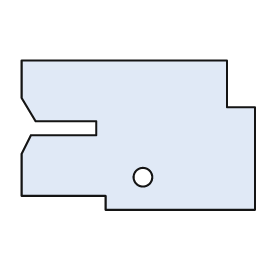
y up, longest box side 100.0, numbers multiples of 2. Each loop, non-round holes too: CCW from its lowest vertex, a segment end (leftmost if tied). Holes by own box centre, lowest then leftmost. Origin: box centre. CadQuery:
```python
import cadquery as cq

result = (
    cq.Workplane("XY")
    .moveTo(-14.0, -32.0)
    .lineTo(50.0, -32.0)
    .lineTo(50.0, 12.0)
    .lineTo(38.0, 12.0)
    .lineTo(38.0, 32.0)
    .lineTo(-50.0, 32.0)
    .lineTo(-50.0, 16.0)
    .lineTo(-44.0, 6.0)
    .lineTo(-18.0, 6.0)
    .lineTo(-18.0, 0.0)
    .lineTo(-46.0, 0.0)
    .lineTo(-50.0, -8.0)
    .lineTo(-50.0, -26.0)
    .lineTo(-14.0, -26.0)
    .close()
    .moveTo(2.0, -18.0)
    .circle(4.0)
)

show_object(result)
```